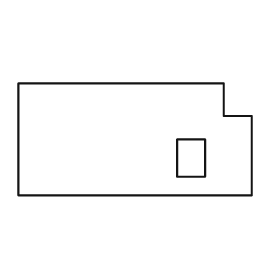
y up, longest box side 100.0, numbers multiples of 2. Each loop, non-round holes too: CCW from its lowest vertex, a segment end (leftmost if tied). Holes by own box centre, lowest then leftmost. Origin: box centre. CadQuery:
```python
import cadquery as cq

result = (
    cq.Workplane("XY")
    .moveTo(-50.0, -24.0)
    .lineTo(50.0, -24.0)
    .lineTo(50.0, 10.0)
    .lineTo(38.0, 10.0)
    .lineTo(38.0, 24.0)
    .lineTo(-50.0, 24.0)
    .close()
    .moveTo(18.0, -16.0)
    .lineTo(30.0, -16.0)
    .lineTo(30.0, 0.0)
    .lineTo(18.0, 0.0)
    .close()
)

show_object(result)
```